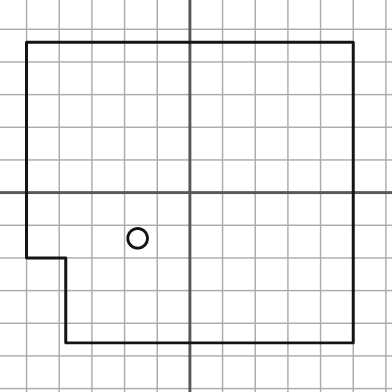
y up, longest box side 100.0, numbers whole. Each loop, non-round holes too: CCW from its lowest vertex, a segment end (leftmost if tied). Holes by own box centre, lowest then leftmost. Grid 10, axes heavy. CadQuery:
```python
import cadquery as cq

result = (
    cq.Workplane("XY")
    .moveTo(-38.0, -46.0)
    .lineTo(50.0, -46.0)
    .lineTo(50.0, 46.0)
    .lineTo(-50.0, 46.0)
    .lineTo(-50.0, -20.0)
    .lineTo(-38.0, -20.0)
    .close()
    .moveTo(-16.0, -14.0)
    .circle(3.0)
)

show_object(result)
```